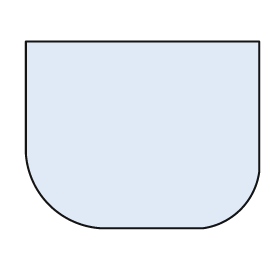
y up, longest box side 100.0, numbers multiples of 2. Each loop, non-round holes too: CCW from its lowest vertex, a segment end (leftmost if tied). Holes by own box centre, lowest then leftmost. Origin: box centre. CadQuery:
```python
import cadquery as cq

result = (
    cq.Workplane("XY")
    .moveTo(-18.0, -40.0)
    .lineTo(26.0, -40.0)
    .threePointArc((42.0, -32.0), (50.0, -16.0))
    .lineTo(50.0, 40.0)
    .lineTo(-50.0, 40.0)
    .lineTo(-50.0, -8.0)
    .threePointArc((-40.0, -30.0), (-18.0, -40.0))
    .close()
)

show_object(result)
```